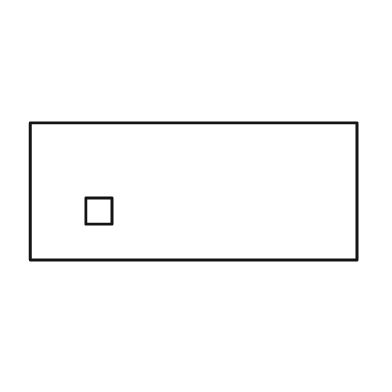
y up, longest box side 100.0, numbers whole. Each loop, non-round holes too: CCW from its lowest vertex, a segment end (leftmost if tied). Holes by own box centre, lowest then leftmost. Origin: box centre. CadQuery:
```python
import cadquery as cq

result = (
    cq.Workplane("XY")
    .moveTo(-50.0, -21.0)
    .lineTo(50.0, -21.0)
    .lineTo(50.0, 21.0)
    .lineTo(-50.0, 21.0)
    .close()
    .moveTo(-33.0, -10.0)
    .lineTo(-25.0, -10.0)
    .lineTo(-25.0, -2.0)
    .lineTo(-33.0, -2.0)
    .close()
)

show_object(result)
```